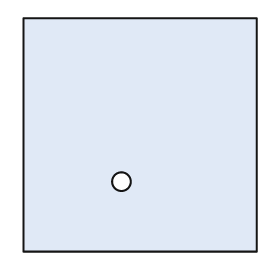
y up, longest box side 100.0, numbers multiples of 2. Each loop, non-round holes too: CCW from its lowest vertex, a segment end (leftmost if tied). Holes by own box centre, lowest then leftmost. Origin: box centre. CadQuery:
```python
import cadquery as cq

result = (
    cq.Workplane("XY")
    .moveTo(-50.0, -50.0)
    .lineTo(50.0, -50.0)
    .lineTo(50.0, 50.0)
    .lineTo(-50.0, 50.0)
    .close()
    .moveTo(-8.0, -20.0)
    .circle(4.0)
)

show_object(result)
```